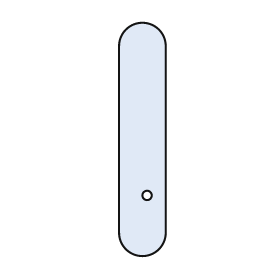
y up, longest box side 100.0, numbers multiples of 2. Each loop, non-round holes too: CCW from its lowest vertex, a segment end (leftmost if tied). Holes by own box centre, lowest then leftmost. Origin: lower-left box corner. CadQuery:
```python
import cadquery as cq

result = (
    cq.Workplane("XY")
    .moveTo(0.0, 10.0)
    .threePointArc((10.0, 0.0), (20.0, 10.0))
    .lineTo(20.0, 90.0)
    .threePointArc((10.0, 100.0), (0.0, 90.0))
    .close()
    .moveTo(12.0, 26.0)
    .circle(2.0)
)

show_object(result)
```